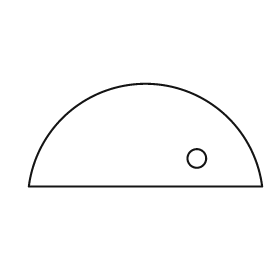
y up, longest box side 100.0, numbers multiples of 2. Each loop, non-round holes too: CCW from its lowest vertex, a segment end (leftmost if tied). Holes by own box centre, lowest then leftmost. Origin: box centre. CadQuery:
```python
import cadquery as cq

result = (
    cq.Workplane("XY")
    .moveTo(-50.0, -22.0)
    .lineTo(50.0, -22.0)
    .threePointArc((0.0, 22.0), (-50.0, -22.0))
    .close()
    .moveTo(22.0, -10.0)
    .circle(4.0)
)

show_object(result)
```